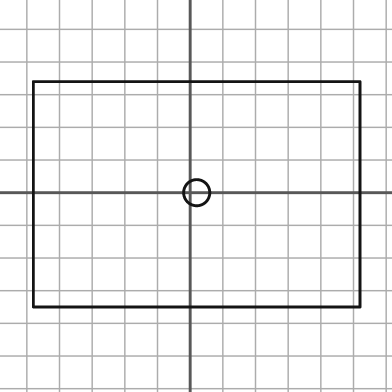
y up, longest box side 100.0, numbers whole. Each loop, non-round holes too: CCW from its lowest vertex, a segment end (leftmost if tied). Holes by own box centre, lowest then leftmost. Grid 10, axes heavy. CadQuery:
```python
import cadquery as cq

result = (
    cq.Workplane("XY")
    .moveTo(-48.0, -35.0)
    .lineTo(52.0, -35.0)
    .lineTo(52.0, 34.0)
    .lineTo(-48.0, 34.0)
    .close()
    .moveTo(2.0, 0.0)
    .circle(4.0)
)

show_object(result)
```